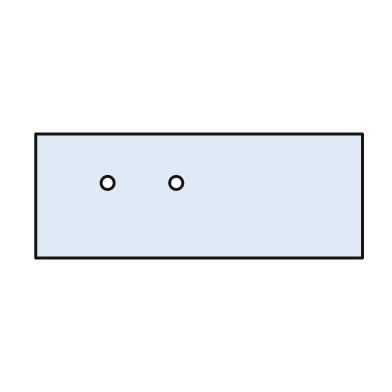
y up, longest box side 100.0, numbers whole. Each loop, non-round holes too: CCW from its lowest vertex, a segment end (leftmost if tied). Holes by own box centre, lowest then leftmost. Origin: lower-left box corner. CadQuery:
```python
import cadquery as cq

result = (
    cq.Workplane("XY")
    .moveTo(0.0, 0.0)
    .lineTo(100.0, 0.0)
    .lineTo(100.0, 38.0)
    .lineTo(0.0, 38.0)
    .close()
    .moveTo(22.0, 23.0)
    .circle(2.0)
    .moveTo(43.0, 23.0)
    .circle(2.0)
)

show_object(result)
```